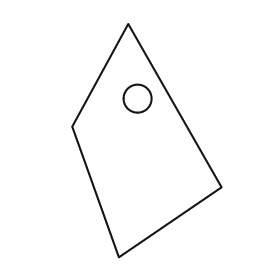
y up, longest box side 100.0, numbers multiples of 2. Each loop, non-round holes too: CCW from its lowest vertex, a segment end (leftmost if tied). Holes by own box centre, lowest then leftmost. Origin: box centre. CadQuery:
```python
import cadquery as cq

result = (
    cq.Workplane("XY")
    .moveTo(-12.0, -50.0)
    .lineTo(32.0, -20.0)
    .lineTo(-8.0, 50.0)
    .lineTo(-32.0, 6.0)
    .close()
    .moveTo(-4.0, 18.0)
    .circle(6.0)
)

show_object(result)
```